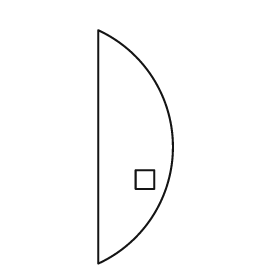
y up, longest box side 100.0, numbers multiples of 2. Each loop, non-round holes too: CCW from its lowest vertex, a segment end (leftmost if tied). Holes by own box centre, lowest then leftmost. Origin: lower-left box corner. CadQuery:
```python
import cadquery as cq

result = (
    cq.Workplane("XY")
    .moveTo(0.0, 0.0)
    .threePointArc((32.0, 50.0), (0.0, 100.0))
    .close()
    .moveTo(16.0, 32.0)
    .lineTo(24.0, 32.0)
    .lineTo(24.0, 40.0)
    .lineTo(16.0, 40.0)
    .close()
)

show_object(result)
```